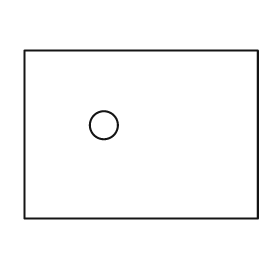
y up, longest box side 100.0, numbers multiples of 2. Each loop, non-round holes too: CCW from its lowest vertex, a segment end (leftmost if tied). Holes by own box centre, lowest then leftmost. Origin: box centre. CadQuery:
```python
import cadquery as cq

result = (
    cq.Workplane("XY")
    .moveTo(-50.0, -36.0)
    .lineTo(50.0, -36.0)
    .lineTo(50.0, 36.0)
    .lineTo(-50.0, 36.0)
    .close()
    .moveTo(-16.0, 4.0)
    .circle(6.0)
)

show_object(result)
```